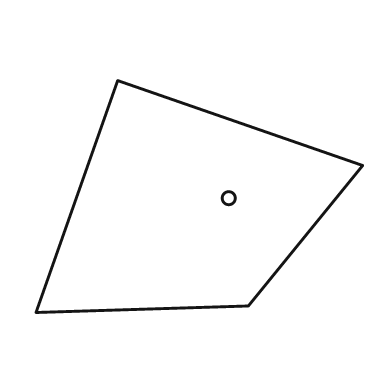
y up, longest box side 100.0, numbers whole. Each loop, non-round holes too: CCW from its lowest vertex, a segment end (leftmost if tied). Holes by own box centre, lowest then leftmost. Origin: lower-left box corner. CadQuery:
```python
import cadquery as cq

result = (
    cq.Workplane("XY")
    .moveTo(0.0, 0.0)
    .lineTo(65.0, 2.0)
    .lineTo(100.0, 45.0)
    .lineTo(25.0, 71.0)
    .close()
    .moveTo(59.0, 35.0)
    .circle(2.0)
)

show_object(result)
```